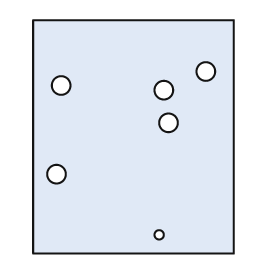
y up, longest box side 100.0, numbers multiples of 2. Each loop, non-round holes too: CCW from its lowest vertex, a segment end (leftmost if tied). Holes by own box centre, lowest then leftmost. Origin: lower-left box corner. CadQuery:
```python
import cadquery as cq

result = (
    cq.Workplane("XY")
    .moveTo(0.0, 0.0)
    .lineTo(86.0, 0.0)
    .lineTo(86.0, 100.0)
    .lineTo(0.0, 100.0)
    .close()
    .moveTo(54.0, 8.0)
    .circle(2.0)
    .moveTo(10.0, 34.0)
    .circle(4.0)
    .moveTo(58.0, 56.0)
    .circle(4.0)
    .moveTo(56.0, 70.0)
    .circle(4.0)
    .moveTo(12.0, 72.0)
    .circle(4.0)
    .moveTo(74.0, 78.0)
    .circle(4.0)
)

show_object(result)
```